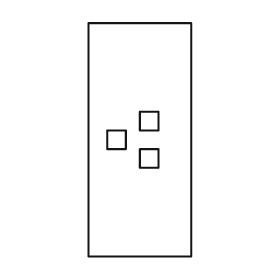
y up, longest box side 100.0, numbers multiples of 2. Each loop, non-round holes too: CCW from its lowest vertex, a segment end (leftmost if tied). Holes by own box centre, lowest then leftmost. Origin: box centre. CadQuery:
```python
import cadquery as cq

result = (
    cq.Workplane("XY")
    .moveTo(-22.0, -50.0)
    .lineTo(22.0, -50.0)
    .lineTo(22.0, 50.0)
    .lineTo(-22.0, 50.0)
    .close()
    .moveTo(0.0, -12.0)
    .lineTo(8.0, -12.0)
    .lineTo(8.0, -4.0)
    .lineTo(0.0, -4.0)
    .close()
    .moveTo(-14.0, -4.0)
    .lineTo(-6.0, -4.0)
    .lineTo(-6.0, 4.0)
    .lineTo(-14.0, 4.0)
    .close()
    .moveTo(0.0, 4.0)
    .lineTo(8.0, 4.0)
    .lineTo(8.0, 12.0)
    .lineTo(0.0, 12.0)
    .close()
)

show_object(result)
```